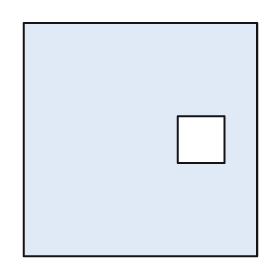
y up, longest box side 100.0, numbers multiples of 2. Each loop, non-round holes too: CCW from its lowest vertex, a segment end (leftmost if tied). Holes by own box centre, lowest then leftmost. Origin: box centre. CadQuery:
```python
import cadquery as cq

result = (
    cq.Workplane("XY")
    .moveTo(-50.0, -50.0)
    .lineTo(50.0, -50.0)
    .lineTo(50.0, 50.0)
    .lineTo(-50.0, 50.0)
    .close()
    .moveTo(16.0, -10.0)
    .lineTo(36.0, -10.0)
    .lineTo(36.0, 10.0)
    .lineTo(16.0, 10.0)
    .close()
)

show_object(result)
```